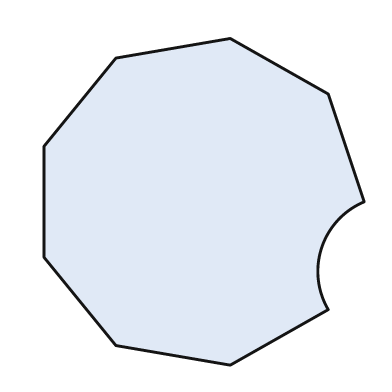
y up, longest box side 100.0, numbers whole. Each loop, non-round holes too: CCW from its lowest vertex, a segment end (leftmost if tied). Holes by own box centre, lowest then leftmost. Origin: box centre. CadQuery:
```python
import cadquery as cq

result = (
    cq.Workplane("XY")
    .moveTo(8.0, -50.0)
    .lineTo(38.0, -33.0)
    .threePointArc((36.0, -14.0), (49.0, 0.0))
    .lineTo(38.0, 33.0)
    .lineTo(8.0, 50.0)
    .lineTo(-27.0, 44.0)
    .lineTo(-49.0, 17.0)
    .lineTo(-49.0, -17.0)
    .lineTo(-27.0, -44.0)
    .close()
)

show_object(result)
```